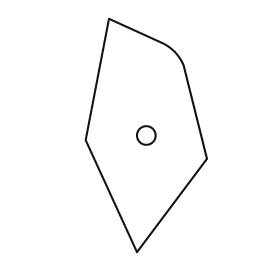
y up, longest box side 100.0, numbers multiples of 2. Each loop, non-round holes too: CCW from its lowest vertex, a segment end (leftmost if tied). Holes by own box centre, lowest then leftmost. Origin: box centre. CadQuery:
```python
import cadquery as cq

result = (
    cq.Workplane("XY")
    .moveTo(-4.0, -50.0)
    .lineTo(26.0, -10.0)
    .lineTo(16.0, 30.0)
    .threePointArc((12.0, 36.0), (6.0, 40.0))
    .lineTo(-16.0, 50.0)
    .lineTo(-26.0, -2.0)
    .close()
    .moveTo(0.0, 0.0)
    .circle(4.0)
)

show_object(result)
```